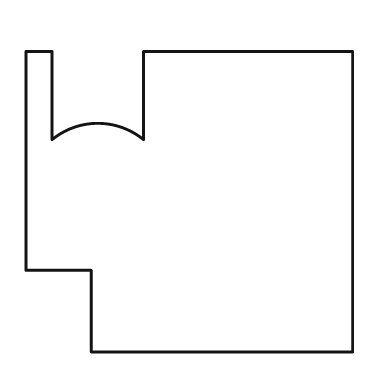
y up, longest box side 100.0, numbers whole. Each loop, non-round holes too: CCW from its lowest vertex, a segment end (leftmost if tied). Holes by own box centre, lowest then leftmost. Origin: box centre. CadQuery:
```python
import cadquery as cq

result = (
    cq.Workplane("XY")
    .moveTo(-30.0, -46.0)
    .lineTo(50.0, -46.0)
    .lineTo(50.0, 46.0)
    .lineTo(-14.0, 46.0)
    .lineTo(-14.0, 19.0)
    .threePointArc((-28.0, 24.0), (-42.0, 19.0))
    .lineTo(-42.0, 46.0)
    .lineTo(-50.0, 46.0)
    .lineTo(-50.0, -21.0)
    .lineTo(-30.0, -21.0)
    .close()
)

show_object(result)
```